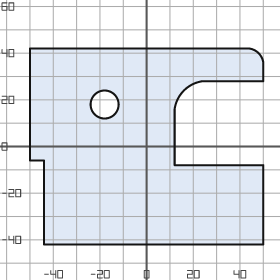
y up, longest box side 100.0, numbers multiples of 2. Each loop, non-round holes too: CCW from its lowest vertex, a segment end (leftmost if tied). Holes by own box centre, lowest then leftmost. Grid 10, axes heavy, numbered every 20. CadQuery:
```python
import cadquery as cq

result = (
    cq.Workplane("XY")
    .moveTo(-44.0, -42.0)
    .lineTo(50.0, -42.0)
    .lineTo(50.0, -8.0)
    .lineTo(12.0, -8.0)
    .lineTo(12.0, 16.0)
    .threePointArc((16.0, 24.0), (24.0, 28.0))
    .lineTo(50.0, 28.0)
    .lineTo(50.0, 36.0)
    .threePointArc((48.0, 40.0), (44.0, 42.0))
    .lineTo(-50.0, 42.0)
    .lineTo(-50.0, -6.0)
    .lineTo(-44.0, -6.0)
    .close()
    .moveTo(-18.0, 18.0)
    .circle(6.0)
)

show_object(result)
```